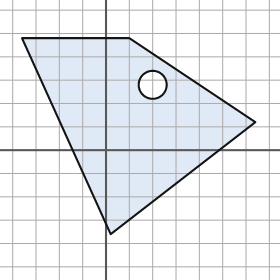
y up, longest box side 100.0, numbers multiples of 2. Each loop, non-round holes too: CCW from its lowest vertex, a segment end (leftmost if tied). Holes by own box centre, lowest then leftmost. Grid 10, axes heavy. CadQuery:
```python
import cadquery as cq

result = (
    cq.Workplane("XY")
    .moveTo(2.0, -36.0)
    .lineTo(64.0, 12.0)
    .lineTo(10.0, 48.0)
    .lineTo(-36.0, 48.0)
    .close()
    .moveTo(20.0, 28.0)
    .circle(6.0)
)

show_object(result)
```